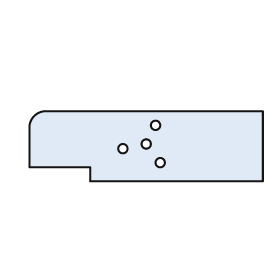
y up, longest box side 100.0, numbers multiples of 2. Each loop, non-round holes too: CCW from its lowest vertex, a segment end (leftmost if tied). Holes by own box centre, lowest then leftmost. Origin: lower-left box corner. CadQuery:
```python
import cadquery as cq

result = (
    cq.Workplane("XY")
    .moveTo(26.0, 0.0)
    .lineTo(100.0, 0.0)
    .lineTo(100.0, 30.0)
    .lineTo(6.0, 30.0)
    .threePointArc((2.0, 28.0), (0.0, 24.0))
    .lineTo(0.0, 6.0)
    .lineTo(26.0, 6.0)
    .close()
    .moveTo(56.0, 8.0)
    .circle(2.0)
    .moveTo(40.0, 14.0)
    .circle(2.0)
    .moveTo(50.0, 16.0)
    .circle(2.0)
    .moveTo(54.0, 24.0)
    .circle(2.0)
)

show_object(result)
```